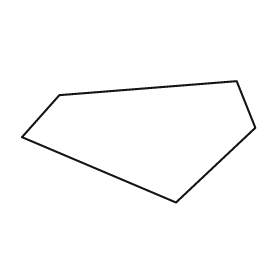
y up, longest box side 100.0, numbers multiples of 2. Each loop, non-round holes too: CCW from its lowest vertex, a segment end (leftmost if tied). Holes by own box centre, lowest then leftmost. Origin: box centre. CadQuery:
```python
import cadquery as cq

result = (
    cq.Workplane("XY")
    .moveTo(16.0, -26.0)
    .lineTo(50.0, 6.0)
    .lineTo(42.0, 26.0)
    .lineTo(-34.0, 20.0)
    .lineTo(-50.0, 2.0)
    .close()
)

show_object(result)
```